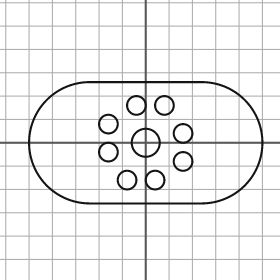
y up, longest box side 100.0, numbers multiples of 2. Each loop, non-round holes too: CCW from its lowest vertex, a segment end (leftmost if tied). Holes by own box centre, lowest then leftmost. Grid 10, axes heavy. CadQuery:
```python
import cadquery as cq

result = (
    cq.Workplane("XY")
    .moveTo(-24.0, -26.0)
    .lineTo(24.0, -26.0)
    .threePointArc((50.0, 0.0), (24.0, 26.0))
    .lineTo(-24.0, 26.0)
    .threePointArc((-50.0, 0.0), (-24.0, -26.0))
    .close()
    .moveTo(-8.0, -16.0)
    .circle(4.0)
    .moveTo(4.0, -16.0)
    .circle(4.0)
    .moveTo(16.0, -8.0)
    .circle(4.0)
    .moveTo(-16.0, -4.0)
    .circle(4.0)
    .moveTo(0.0, 0.0)
    .circle(6.0)
    .moveTo(16.0, 4.0)
    .circle(4.0)
    .moveTo(-16.0, 8.0)
    .circle(4.0)
    .moveTo(-4.0, 16.0)
    .circle(4.0)
    .moveTo(8.0, 16.0)
    .circle(4.0)
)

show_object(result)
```